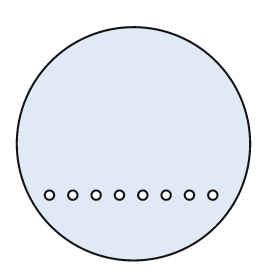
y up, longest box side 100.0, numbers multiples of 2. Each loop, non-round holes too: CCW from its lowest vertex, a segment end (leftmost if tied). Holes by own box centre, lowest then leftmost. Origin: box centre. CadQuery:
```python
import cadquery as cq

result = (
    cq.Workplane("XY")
    .moveTo(0.0, 0.0)
    .circle(50.0)
    .moveTo(-36.0, -22.0)
    .circle(2.0)
    .moveTo(-26.0, -22.0)
    .circle(2.0)
    .moveTo(-16.0, -22.0)
    .circle(2.0)
    .moveTo(-6.0, -22.0)
    .circle(2.0)
    .moveTo(4.0, -22.0)
    .circle(2.0)
    .moveTo(14.0, -22.0)
    .circle(2.0)
    .moveTo(24.0, -22.0)
    .circle(2.0)
    .moveTo(34.0, -22.0)
    .circle(2.0)
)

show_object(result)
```